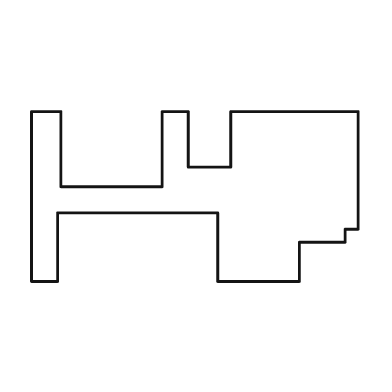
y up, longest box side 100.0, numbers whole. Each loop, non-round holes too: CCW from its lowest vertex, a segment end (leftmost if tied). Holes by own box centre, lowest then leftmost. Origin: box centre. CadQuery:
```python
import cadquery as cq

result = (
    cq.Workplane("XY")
    .moveTo(-50.0, -26.0)
    .lineTo(-42.0, -26.0)
    .lineTo(-42.0, -5.0)
    .lineTo(7.0, -5.0)
    .lineTo(7.0, -26.0)
    .lineTo(32.0, -26.0)
    .lineTo(32.0, -14.0)
    .lineTo(46.0, -14.0)
    .lineTo(46.0, -10.0)
    .lineTo(50.0, -10.0)
    .lineTo(50.0, 26.0)
    .lineTo(11.0, 26.0)
    .lineTo(11.0, 9.0)
    .lineTo(-2.0, 9.0)
    .lineTo(-2.0, 26.0)
    .lineTo(-10.0, 26.0)
    .lineTo(-10.0, 3.0)
    .lineTo(-41.0, 3.0)
    .lineTo(-41.0, 26.0)
    .lineTo(-50.0, 26.0)
    .close()
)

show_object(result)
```